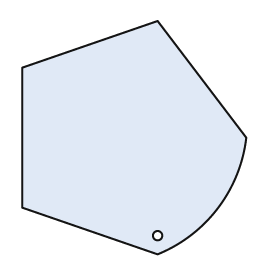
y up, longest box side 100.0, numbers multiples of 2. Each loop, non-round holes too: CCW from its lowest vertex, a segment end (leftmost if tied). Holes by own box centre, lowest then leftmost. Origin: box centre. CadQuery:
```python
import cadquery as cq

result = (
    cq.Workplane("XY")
    .moveTo(10.0, -50.0)
    .threePointArc((36.0, -30.0), (48.0, 0.0))
    .lineTo(10.0, 50.0)
    .lineTo(-48.0, 30.0)
    .lineTo(-48.0, -30.0)
    .close()
    .moveTo(10.0, -42.0)
    .circle(2.0)
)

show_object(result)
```